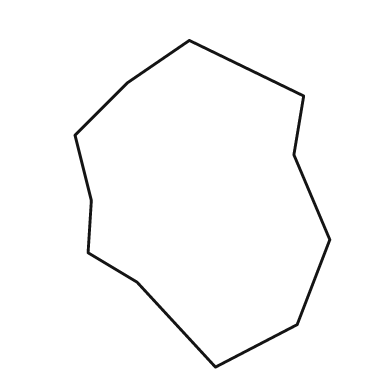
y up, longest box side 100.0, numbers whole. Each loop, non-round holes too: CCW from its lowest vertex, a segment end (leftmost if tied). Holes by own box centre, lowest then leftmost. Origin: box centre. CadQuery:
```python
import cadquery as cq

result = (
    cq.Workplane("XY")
    .moveTo(4.0, -50.0)
    .lineTo(29.0, -37.0)
    .lineTo(39.0, -11.0)
    .lineTo(28.0, 15.0)
    .lineTo(31.0, 33.0)
    .lineTo(-4.0, 50.0)
    .lineTo(-23.0, 37.0)
    .lineTo(-39.0, 21.0)
    .lineTo(-34.0, 1.0)
    .lineTo(-35.0, -15.0)
    .lineTo(-20.0, -24.0)
    .close()
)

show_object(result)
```